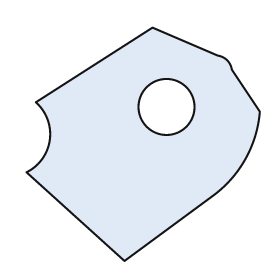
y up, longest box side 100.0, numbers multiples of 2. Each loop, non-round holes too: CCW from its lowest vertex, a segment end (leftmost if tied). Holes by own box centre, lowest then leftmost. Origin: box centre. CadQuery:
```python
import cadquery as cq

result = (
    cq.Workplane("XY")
    .moveTo(-8.0, -50.0)
    .lineTo(30.0, -22.0)
    .threePointArc((44.0, -6.0), (50.0, 14.0))
    .lineTo(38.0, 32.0)
    .threePointArc((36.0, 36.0), (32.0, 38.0))
    .lineTo(4.0, 50.0)
    .lineTo(-46.0, 18.0)
    .threePointArc((-40.0, 2.0), (-50.0, -12.0))
    .close()
    .moveTo(10.0, 16.0)
    .circle(12.0)
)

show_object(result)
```